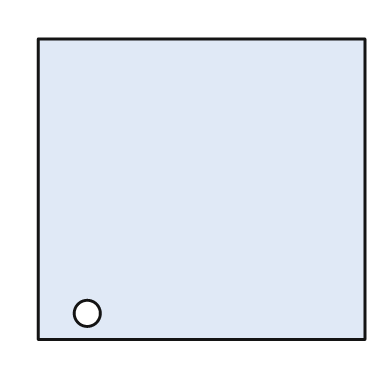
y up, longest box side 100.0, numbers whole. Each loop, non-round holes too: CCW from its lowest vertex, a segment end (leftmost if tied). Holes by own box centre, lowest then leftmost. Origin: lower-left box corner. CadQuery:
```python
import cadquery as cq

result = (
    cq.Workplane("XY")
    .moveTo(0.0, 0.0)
    .lineTo(100.0, 0.0)
    .lineTo(100.0, 92.0)
    .lineTo(0.0, 92.0)
    .close()
    .moveTo(15.0, 8.0)
    .circle(4.0)
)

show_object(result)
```